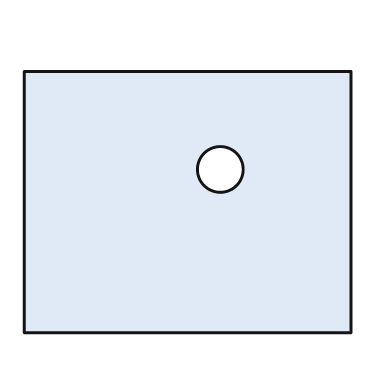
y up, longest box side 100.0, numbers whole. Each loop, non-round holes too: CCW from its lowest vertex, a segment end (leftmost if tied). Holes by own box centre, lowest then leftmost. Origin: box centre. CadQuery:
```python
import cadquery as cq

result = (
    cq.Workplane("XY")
    .moveTo(-50.0, -40.0)
    .lineTo(50.0, -40.0)
    .lineTo(50.0, 40.0)
    .lineTo(-50.0, 40.0)
    .close()
    .moveTo(10.0, 10.0)
    .circle(7.0)
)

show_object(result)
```